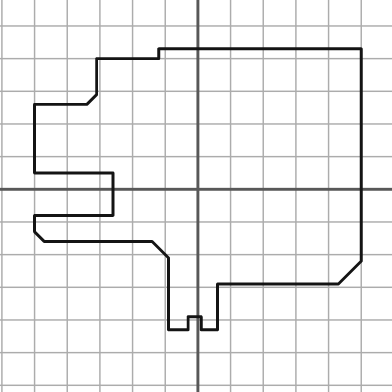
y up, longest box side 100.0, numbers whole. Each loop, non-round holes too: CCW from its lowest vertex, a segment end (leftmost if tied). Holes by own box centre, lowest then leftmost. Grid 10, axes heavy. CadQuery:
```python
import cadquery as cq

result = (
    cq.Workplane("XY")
    .moveTo(-9.0, -43.0)
    .lineTo(-3.0, -43.0)
    .lineTo(-3.0, -39.0)
    .lineTo(1.0, -39.0)
    .lineTo(1.0, -43.0)
    .lineTo(6.0, -43.0)
    .lineTo(6.0, -29.0)
    .lineTo(43.0, -29.0)
    .lineTo(50.0, -22.0)
    .lineTo(50.0, 43.0)
    .lineTo(-12.0, 43.0)
    .lineTo(-12.0, 40.0)
    .lineTo(-31.0, 40.0)
    .lineTo(-31.0, 29.0)
    .lineTo(-34.0, 26.0)
    .lineTo(-50.0, 26.0)
    .lineTo(-50.0, 5.0)
    .lineTo(-26.0, 5.0)
    .lineTo(-26.0, -8.0)
    .lineTo(-50.0, -8.0)
    .lineTo(-50.0, -13.0)
    .lineTo(-47.0, -16.0)
    .lineTo(-14.0, -16.0)
    .lineTo(-9.0, -21.0)
    .close()
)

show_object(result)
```